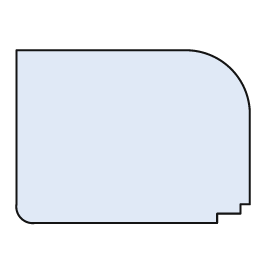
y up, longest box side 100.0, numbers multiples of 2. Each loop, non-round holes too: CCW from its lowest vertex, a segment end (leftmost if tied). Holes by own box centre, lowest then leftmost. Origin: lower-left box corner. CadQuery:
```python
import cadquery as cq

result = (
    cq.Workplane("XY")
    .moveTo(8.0, 0.0)
    .lineTo(86.0, 0.0)
    .lineTo(86.0, 4.0)
    .lineTo(96.0, 4.0)
    .lineTo(96.0, 8.0)
    .lineTo(100.0, 8.0)
    .lineTo(100.0, 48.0)
    .threePointArc((92.0, 66.0), (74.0, 74.0))
    .lineTo(0.0, 74.0)
    .lineTo(0.0, 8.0)
    .threePointArc((2.0, 2.0), (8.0, 0.0))
    .close()
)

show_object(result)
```